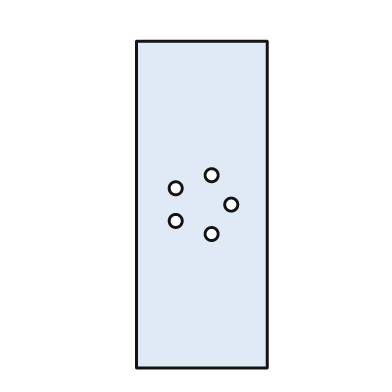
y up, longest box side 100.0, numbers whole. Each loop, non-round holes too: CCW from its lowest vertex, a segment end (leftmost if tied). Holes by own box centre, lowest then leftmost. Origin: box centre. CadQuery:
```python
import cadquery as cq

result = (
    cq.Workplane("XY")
    .moveTo(-20.0, -50.0)
    .lineTo(20.0, -50.0)
    .lineTo(20.0, 50.0)
    .lineTo(-20.0, 50.0)
    .close()
    .moveTo(3.0, -9.0)
    .circle(2.0)
    .moveTo(-8.0, -5.0)
    .circle(2.0)
    .moveTo(9.0, 0.0)
    .circle(2.0)
    .moveTo(-8.0, 5.0)
    .circle(2.0)
    .moveTo(3.0, 9.0)
    .circle(2.0)
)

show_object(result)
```